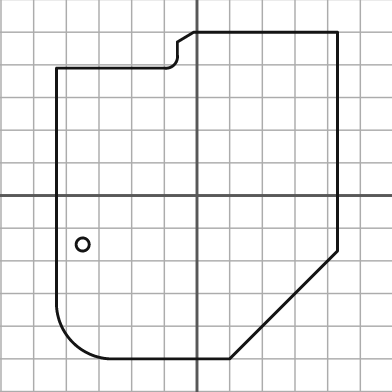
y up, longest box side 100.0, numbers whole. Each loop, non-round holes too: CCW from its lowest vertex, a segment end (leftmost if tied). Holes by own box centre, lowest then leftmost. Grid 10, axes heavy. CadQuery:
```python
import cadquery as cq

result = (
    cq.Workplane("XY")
    .moveTo(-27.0, -50.0)
    .lineTo(10.0, -50.0)
    .lineTo(43.0, -17.0)
    .lineTo(43.0, 50.0)
    .lineTo(-1.0, 50.0)
    .lineTo(-6.0, 47.0)
    .lineTo(-6.0, 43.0)
    .threePointArc((-7.0, 40.0), (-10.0, 39.0))
    .lineTo(-43.0, 39.0)
    .lineTo(-43.0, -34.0)
    .threePointArc((-38.0, -45.0), (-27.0, -50.0))
    .close()
    .moveTo(-35.0, -15.0)
    .circle(2.0)
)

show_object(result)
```